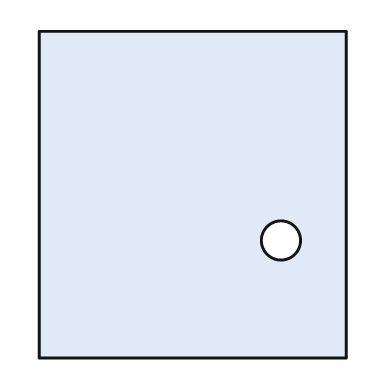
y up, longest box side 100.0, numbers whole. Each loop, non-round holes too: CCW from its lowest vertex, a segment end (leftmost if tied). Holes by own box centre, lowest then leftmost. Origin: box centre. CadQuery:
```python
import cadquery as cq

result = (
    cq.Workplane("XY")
    .moveTo(-47.0, -50.0)
    .lineTo(47.0, -50.0)
    .lineTo(47.0, 50.0)
    .lineTo(-47.0, 50.0)
    .close()
    .moveTo(27.0, -14.0)
    .circle(6.0)
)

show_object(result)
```